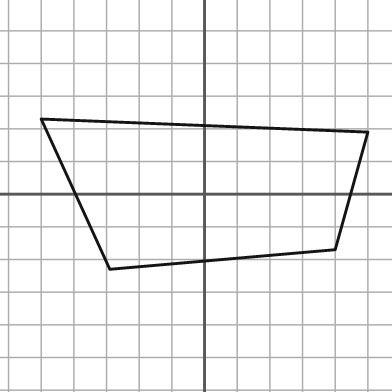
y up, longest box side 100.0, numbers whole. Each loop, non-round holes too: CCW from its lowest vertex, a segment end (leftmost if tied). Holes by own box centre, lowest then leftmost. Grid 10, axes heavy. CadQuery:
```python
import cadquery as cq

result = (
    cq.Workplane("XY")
    .moveTo(-29.0, -23.0)
    .lineTo(40.0, -17.0)
    .lineTo(50.0, 19.0)
    .lineTo(-50.0, 23.0)
    .close()
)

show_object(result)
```